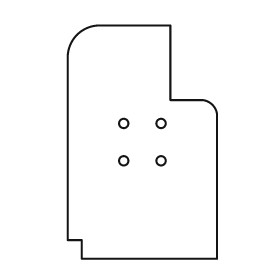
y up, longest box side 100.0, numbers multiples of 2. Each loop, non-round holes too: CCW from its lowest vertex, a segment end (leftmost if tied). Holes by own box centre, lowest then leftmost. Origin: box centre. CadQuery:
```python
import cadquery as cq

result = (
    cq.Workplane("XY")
    .moveTo(-26.0, -50.0)
    .lineTo(32.0, -50.0)
    .lineTo(32.0, 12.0)
    .threePointArc((30.0, 16.0), (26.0, 18.0))
    .lineTo(12.0, 18.0)
    .lineTo(12.0, 50.0)
    .lineTo(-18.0, 50.0)
    .threePointArc((-28.0, 46.0), (-32.0, 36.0))
    .lineTo(-32.0, -42.0)
    .lineTo(-26.0, -42.0)
    .close()
    .moveTo(-8.0, -8.0)
    .circle(2.0)
    .moveTo(8.0, -8.0)
    .circle(2.0)
    .moveTo(-8.0, 8.0)
    .circle(2.0)
    .moveTo(8.0, 8.0)
    .circle(2.0)
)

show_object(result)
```